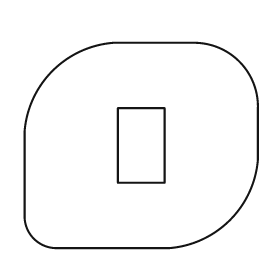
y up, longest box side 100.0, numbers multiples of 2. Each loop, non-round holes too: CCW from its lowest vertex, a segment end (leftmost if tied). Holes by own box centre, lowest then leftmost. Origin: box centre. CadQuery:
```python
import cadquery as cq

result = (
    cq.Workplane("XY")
    .moveTo(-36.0, -44.0)
    .lineTo(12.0, -44.0)
    .threePointArc((38.0, -32.0), (50.0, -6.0))
    .lineTo(50.0, 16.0)
    .threePointArc((42.0, 36.0), (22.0, 44.0))
    .lineTo(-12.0, 44.0)
    .threePointArc((-38.0, 32.0), (-50.0, 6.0))
    .lineTo(-50.0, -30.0)
    .threePointArc((-46.0, -40.0), (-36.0, -44.0))
    .close()
    .moveTo(-10.0, -16.0)
    .lineTo(10.0, -16.0)
    .lineTo(10.0, 16.0)
    .lineTo(-10.0, 16.0)
    .close()
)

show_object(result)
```